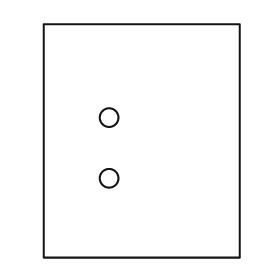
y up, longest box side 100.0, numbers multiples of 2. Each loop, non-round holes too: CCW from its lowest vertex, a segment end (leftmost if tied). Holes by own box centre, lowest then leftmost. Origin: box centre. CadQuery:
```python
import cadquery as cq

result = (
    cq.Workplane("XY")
    .moveTo(-42.0, -50.0)
    .lineTo(42.0, -50.0)
    .lineTo(42.0, 50.0)
    .lineTo(-42.0, 50.0)
    .close()
    .moveTo(-14.0, -16.0)
    .circle(4.0)
    .moveTo(-14.0, 10.0)
    .circle(4.0)
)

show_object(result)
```